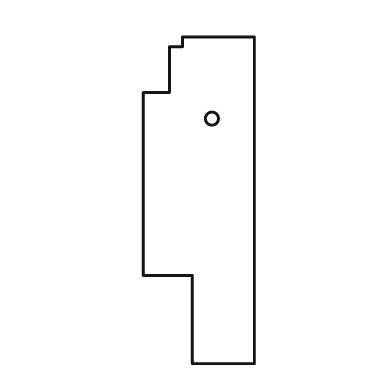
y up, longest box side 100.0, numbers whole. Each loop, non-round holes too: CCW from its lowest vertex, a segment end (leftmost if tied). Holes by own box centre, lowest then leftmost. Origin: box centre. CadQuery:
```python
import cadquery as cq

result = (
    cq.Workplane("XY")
    .moveTo(-2.0, -50.0)
    .lineTo(17.0, -50.0)
    .lineTo(17.0, 50.0)
    .lineTo(-5.0, 50.0)
    .lineTo(-5.0, 47.0)
    .lineTo(-9.0, 47.0)
    .lineTo(-9.0, 33.0)
    .lineTo(-17.0, 33.0)
    .lineTo(-17.0, -23.0)
    .lineTo(-2.0, -23.0)
    .close()
    .moveTo(4.0, 25.0)
    .circle(2.0)
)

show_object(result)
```